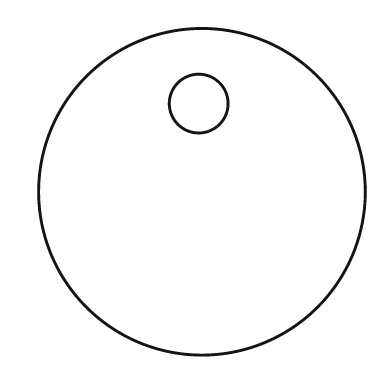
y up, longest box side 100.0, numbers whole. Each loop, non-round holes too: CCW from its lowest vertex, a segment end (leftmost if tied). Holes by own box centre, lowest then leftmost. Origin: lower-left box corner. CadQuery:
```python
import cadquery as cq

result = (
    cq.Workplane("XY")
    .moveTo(50.0, 50.0)
    .circle(50.0)
    .moveTo(49.0, 77.0)
    .circle(9.0)
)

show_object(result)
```